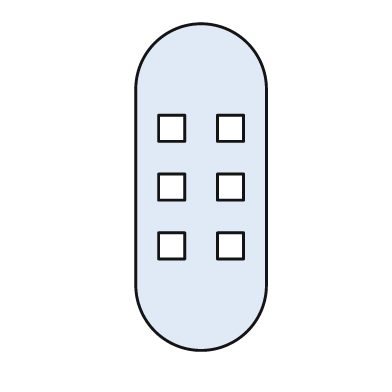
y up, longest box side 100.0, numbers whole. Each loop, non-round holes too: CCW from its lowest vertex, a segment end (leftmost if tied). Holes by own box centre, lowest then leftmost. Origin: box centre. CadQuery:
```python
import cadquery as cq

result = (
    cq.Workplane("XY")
    .moveTo(-20.0, -30.0)
    .threePointArc((0.0, -50.0), (20.0, -30.0))
    .lineTo(20.0, 30.0)
    .threePointArc((0.0, 50.0), (-20.0, 30.0))
    .close()
    .moveTo(-13.0, -22.0)
    .lineTo(-5.0, -22.0)
    .lineTo(-5.0, -14.0)
    .lineTo(-13.0, -14.0)
    .close()
    .moveTo(5.0, -22.0)
    .lineTo(13.0, -22.0)
    .lineTo(13.0, -14.0)
    .lineTo(5.0, -14.0)
    .close()
    .moveTo(-13.0, -4.0)
    .lineTo(-5.0, -4.0)
    .lineTo(-5.0, 4.0)
    .lineTo(-13.0, 4.0)
    .close()
    .moveTo(5.0, -4.0)
    .lineTo(13.0, -4.0)
    .lineTo(13.0, 4.0)
    .lineTo(5.0, 4.0)
    .close()
    .moveTo(-13.0, 14.0)
    .lineTo(-5.0, 14.0)
    .lineTo(-5.0, 22.0)
    .lineTo(-13.0, 22.0)
    .close()
    .moveTo(5.0, 14.0)
    .lineTo(13.0, 14.0)
    .lineTo(13.0, 22.0)
    .lineTo(5.0, 22.0)
    .close()
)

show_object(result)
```